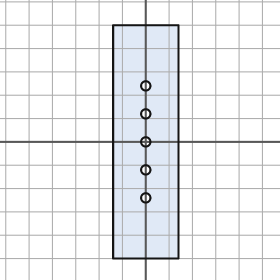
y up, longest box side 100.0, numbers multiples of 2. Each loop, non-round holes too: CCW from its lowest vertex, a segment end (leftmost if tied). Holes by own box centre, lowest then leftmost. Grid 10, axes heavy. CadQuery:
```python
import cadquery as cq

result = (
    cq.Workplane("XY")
    .moveTo(-14.0, -50.0)
    .lineTo(14.0, -50.0)
    .lineTo(14.0, 50.0)
    .lineTo(-14.0, 50.0)
    .close()
    .moveTo(0.0, -24.0)
    .circle(2.0)
    .moveTo(0.0, -12.0)
    .circle(2.0)
    .moveTo(0.0, 0.0)
    .circle(2.0)
    .moveTo(0.0, 12.0)
    .circle(2.0)
    .moveTo(0.0, 24.0)
    .circle(2.0)
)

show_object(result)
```